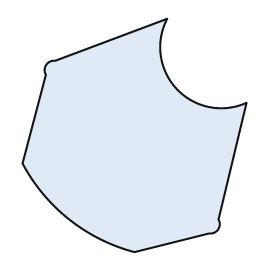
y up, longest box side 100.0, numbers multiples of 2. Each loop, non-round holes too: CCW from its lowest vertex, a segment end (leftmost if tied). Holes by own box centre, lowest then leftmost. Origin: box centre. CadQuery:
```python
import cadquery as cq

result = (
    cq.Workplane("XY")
    .moveTo(0.0, -50.0)
    .lineTo(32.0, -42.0)
    .threePointArc((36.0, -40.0), (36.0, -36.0))
    .lineTo(48.0, 14.0)
    .threePointArc((18.0, 20.0), (14.0, 50.0))
    .lineTo(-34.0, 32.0)
    .threePointArc((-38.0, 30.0), (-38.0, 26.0))
    .lineTo(-48.0, -12.0)
    .threePointArc((-28.0, -36.0), (0.0, -50.0))
    .close()
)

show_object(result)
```